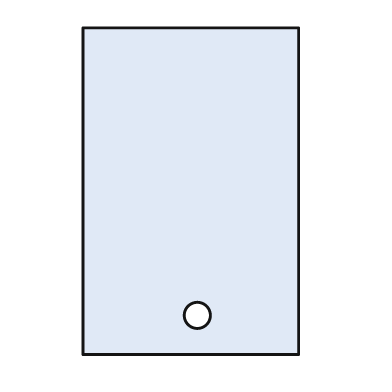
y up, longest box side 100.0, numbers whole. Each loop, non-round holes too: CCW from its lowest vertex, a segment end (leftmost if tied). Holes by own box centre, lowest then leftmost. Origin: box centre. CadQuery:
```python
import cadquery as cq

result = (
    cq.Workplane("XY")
    .moveTo(-33.0, -50.0)
    .lineTo(33.0, -50.0)
    .lineTo(33.0, 50.0)
    .lineTo(-33.0, 50.0)
    .close()
    .moveTo(2.0, -38.0)
    .circle(4.0)
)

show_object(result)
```